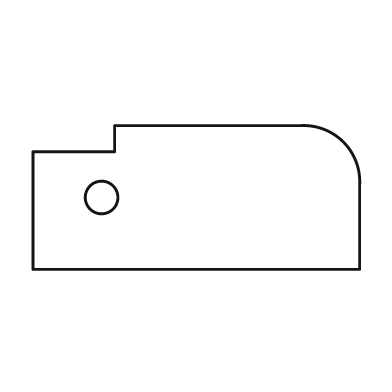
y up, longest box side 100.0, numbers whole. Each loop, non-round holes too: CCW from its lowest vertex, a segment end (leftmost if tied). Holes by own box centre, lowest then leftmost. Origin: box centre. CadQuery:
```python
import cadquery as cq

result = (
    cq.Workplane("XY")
    .moveTo(-50.0, -22.0)
    .lineTo(50.0, -22.0)
    .lineTo(50.0, 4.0)
    .threePointArc((45.0, 17.0), (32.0, 22.0))
    .lineTo(-25.0, 22.0)
    .lineTo(-25.0, 14.0)
    .lineTo(-50.0, 14.0)
    .close()
    .moveTo(-29.0, 0.0)
    .circle(5.0)
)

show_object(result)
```